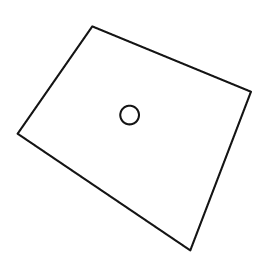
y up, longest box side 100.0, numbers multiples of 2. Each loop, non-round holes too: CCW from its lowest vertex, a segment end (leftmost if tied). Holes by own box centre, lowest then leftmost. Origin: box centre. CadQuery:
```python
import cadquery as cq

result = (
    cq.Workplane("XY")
    .moveTo(24.0, -48.0)
    .lineTo(50.0, 20.0)
    .lineTo(-18.0, 48.0)
    .lineTo(-50.0, 2.0)
    .close()
    .moveTo(-2.0, 10.0)
    .circle(4.0)
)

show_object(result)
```